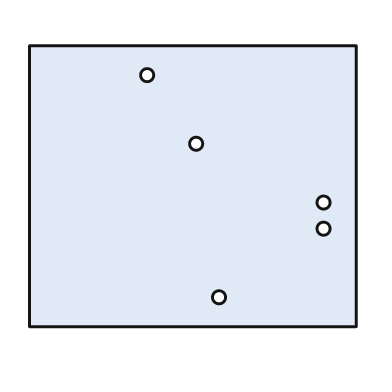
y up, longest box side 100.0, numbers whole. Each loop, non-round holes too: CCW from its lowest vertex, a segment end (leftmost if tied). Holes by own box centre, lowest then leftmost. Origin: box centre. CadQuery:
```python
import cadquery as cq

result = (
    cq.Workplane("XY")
    .moveTo(-50.0, -43.0)
    .lineTo(50.0, -43.0)
    .lineTo(50.0, 43.0)
    .lineTo(-50.0, 43.0)
    .close()
    .moveTo(8.0, -34.0)
    .circle(2.0)
    .moveTo(40.0, -13.0)
    .circle(2.0)
    .moveTo(40.0, -5.0)
    .circle(2.0)
    .moveTo(1.0, 13.0)
    .circle(2.0)
    .moveTo(-14.0, 34.0)
    .circle(2.0)
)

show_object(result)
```